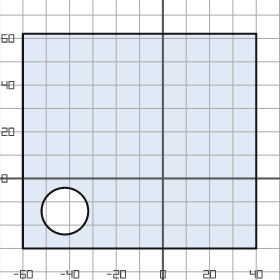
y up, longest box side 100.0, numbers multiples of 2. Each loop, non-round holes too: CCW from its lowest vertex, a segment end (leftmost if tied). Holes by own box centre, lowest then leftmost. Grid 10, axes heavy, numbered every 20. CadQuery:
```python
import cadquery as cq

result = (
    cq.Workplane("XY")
    .moveTo(-60.0, -30.0)
    .lineTo(40.0, -30.0)
    .lineTo(40.0, 62.0)
    .lineTo(-60.0, 62.0)
    .close()
    .moveTo(-42.0, -14.0)
    .circle(10.0)
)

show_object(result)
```